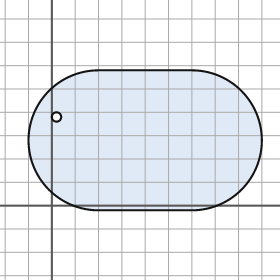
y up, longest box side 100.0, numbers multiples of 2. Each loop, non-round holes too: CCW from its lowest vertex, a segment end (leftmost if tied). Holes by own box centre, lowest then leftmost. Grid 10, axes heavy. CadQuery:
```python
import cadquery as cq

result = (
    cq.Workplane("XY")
    .moveTo(20.0, -2.0)
    .lineTo(60.0, -2.0)
    .threePointArc((90.0, 28.0), (60.0, 58.0))
    .lineTo(20.0, 58.0)
    .threePointArc((-10.0, 28.0), (20.0, -2.0))
    .close()
    .moveTo(2.0, 38.0)
    .circle(2.0)
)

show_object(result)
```